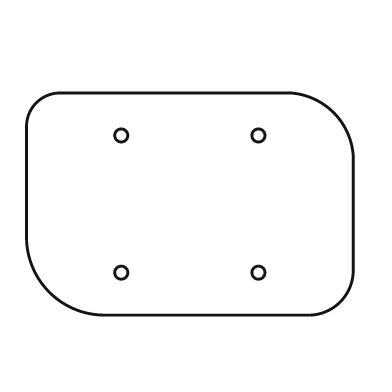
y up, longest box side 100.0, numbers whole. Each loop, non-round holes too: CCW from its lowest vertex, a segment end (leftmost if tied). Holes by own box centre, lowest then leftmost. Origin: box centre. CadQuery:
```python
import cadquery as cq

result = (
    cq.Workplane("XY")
    .moveTo(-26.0, -34.0)
    .lineTo(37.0, -34.0)
    .threePointArc((46.0, -30.0), (50.0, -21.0))
    .lineTo(50.0, 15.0)
    .threePointArc((44.0, 28.0), (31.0, 34.0))
    .lineTo(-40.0, 34.0)
    .threePointArc((-47.0, 31.0), (-50.0, 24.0))
    .lineTo(-50.0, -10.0)
    .threePointArc((-43.0, -27.0), (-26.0, -34.0))
    .close()
    .moveTo(-21.0, -21.0)
    .circle(2.0)
    .moveTo(21.0, -21.0)
    .circle(2.0)
    .moveTo(-21.0, 21.0)
    .circle(2.0)
    .moveTo(21.0, 21.0)
    .circle(2.0)
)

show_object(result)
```